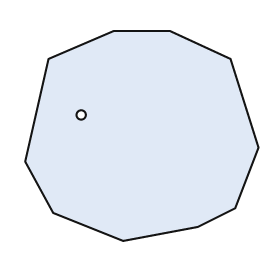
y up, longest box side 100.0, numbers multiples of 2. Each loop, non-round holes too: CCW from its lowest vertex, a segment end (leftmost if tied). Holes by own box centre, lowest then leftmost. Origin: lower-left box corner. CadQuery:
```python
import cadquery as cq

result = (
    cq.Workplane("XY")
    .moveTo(42.0, 0.0)
    .lineTo(74.0, 6.0)
    .lineTo(90.0, 14.0)
    .lineTo(100.0, 40.0)
    .lineTo(88.0, 78.0)
    .lineTo(62.0, 90.0)
    .lineTo(38.0, 90.0)
    .lineTo(10.0, 78.0)
    .lineTo(0.0, 34.0)
    .lineTo(12.0, 12.0)
    .close()
    .moveTo(24.0, 54.0)
    .circle(2.0)
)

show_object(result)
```